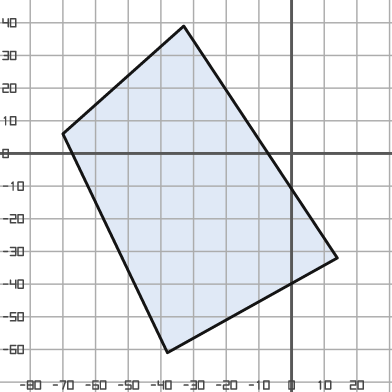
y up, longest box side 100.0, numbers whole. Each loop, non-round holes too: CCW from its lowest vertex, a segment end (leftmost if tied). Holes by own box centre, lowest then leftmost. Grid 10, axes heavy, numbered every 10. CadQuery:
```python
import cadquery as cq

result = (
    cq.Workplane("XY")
    .moveTo(-38.0, -61.0)
    .lineTo(14.0, -32.0)
    .lineTo(-33.0, 39.0)
    .lineTo(-70.0, 6.0)
    .close()
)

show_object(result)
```